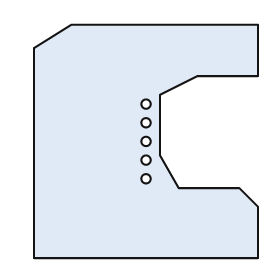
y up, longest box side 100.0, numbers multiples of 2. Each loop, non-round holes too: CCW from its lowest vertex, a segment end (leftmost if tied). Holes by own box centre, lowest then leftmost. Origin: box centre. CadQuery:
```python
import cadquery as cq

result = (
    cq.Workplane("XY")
    .moveTo(-48.0, -50.0)
    .lineTo(48.0, -50.0)
    .lineTo(48.0, -28.0)
    .lineTo(40.0, -20.0)
    .lineTo(14.0, -20.0)
    .lineTo(6.0, -6.0)
    .lineTo(6.0, 20.0)
    .lineTo(22.0, 28.0)
    .lineTo(48.0, 28.0)
    .lineTo(48.0, 50.0)
    .lineTo(-32.0, 50.0)
    .lineTo(-48.0, 40.0)
    .close()
    .moveTo(0.0, -16.0)
    .circle(2.0)
    .moveTo(0.0, -8.0)
    .circle(2.0)
    .moveTo(0.0, 0.0)
    .circle(2.0)
    .moveTo(0.0, 8.0)
    .circle(2.0)
    .moveTo(0.0, 16.0)
    .circle(2.0)
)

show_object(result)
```